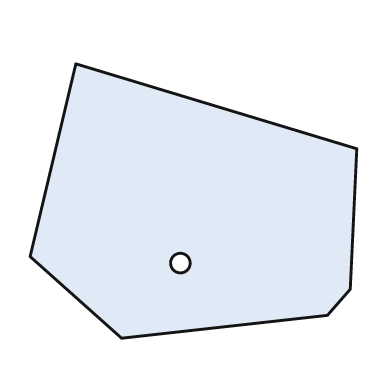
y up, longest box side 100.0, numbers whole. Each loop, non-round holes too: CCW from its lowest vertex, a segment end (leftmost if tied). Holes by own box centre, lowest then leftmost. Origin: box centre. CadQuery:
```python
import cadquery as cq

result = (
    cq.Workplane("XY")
    .moveTo(-22.0, -42.0)
    .lineTo(41.0, -35.0)
    .lineTo(48.0, -27.0)
    .lineTo(50.0, 16.0)
    .lineTo(-36.0, 42.0)
    .lineTo(-50.0, -17.0)
    .close()
    .moveTo(-4.0, -19.0)
    .circle(3.0)
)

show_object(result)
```